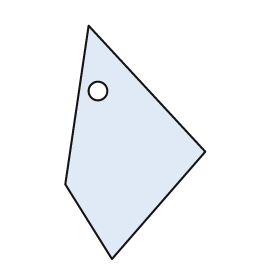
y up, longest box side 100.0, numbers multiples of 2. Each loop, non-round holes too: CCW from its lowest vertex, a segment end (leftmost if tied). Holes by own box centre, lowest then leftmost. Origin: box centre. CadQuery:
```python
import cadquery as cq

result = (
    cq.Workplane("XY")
    .moveTo(-10.0, -50.0)
    .lineTo(30.0, -4.0)
    .lineTo(-20.0, 50.0)
    .lineTo(-30.0, -18.0)
    .close()
    .moveTo(-16.0, 22.0)
    .circle(4.0)
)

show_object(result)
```